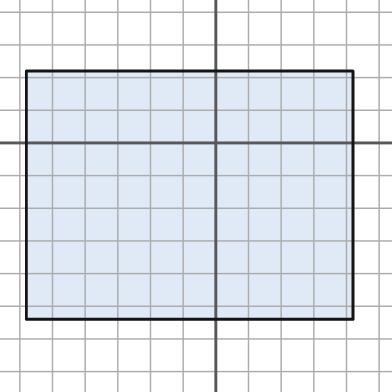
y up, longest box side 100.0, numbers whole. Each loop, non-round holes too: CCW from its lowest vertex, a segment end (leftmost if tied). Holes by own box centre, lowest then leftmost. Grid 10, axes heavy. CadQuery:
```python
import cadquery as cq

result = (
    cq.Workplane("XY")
    .moveTo(-58.0, -54.0)
    .lineTo(42.0, -54.0)
    .lineTo(42.0, 22.0)
    .lineTo(-58.0, 22.0)
    .close()
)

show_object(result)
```